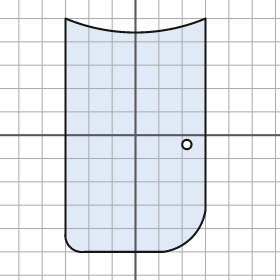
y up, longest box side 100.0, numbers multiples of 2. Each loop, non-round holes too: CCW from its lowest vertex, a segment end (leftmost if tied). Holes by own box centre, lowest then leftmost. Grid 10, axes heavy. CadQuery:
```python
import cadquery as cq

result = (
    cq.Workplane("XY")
    .moveTo(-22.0, -50.0)
    .lineTo(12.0, -50.0)
    .threePointArc((24.0, -44.0), (30.0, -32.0))
    .lineTo(30.0, 50.0)
    .threePointArc((0.0, 44.0), (-30.0, 50.0))
    .lineTo(-30.0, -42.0)
    .threePointArc((-28.0, -48.0), (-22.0, -50.0))
    .close()
    .moveTo(22.0, -4.0)
    .circle(2.0)
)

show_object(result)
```